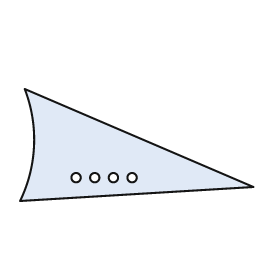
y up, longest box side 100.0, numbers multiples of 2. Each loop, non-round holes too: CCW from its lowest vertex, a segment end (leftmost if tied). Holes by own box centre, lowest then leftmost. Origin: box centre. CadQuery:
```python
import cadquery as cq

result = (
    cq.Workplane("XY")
    .moveTo(-50.0, -24.0)
    .lineTo(50.0, -18.0)
    .lineTo(-48.0, 24.0)
    .threePointArc((-44.0, 0.0), (-50.0, -24.0))
    .close()
    .moveTo(-26.0, -14.0)
    .circle(2.0)
    .moveTo(-18.0, -14.0)
    .circle(2.0)
    .moveTo(-10.0, -14.0)
    .circle(2.0)
    .moveTo(-2.0, -14.0)
    .circle(2.0)
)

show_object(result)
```